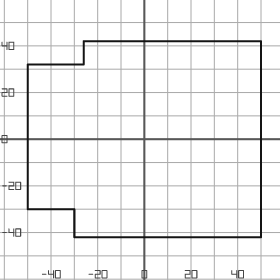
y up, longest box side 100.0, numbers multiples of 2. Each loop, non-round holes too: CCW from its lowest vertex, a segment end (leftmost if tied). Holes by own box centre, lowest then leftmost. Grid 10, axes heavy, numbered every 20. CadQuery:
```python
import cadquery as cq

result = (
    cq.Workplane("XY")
    .moveTo(-30.0, -42.0)
    .lineTo(50.0, -42.0)
    .lineTo(50.0, 42.0)
    .lineTo(-26.0, 42.0)
    .lineTo(-26.0, 32.0)
    .lineTo(-50.0, 32.0)
    .lineTo(-50.0, -30.0)
    .lineTo(-30.0, -30.0)
    .close()
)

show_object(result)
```